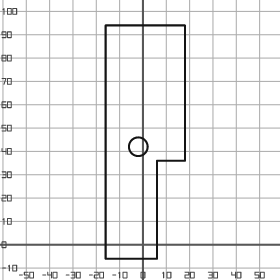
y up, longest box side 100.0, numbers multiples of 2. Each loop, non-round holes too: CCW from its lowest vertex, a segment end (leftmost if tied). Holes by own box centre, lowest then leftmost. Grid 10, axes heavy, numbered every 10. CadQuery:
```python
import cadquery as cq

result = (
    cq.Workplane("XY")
    .moveTo(-16.0, -6.0)
    .lineTo(6.0, -6.0)
    .lineTo(6.0, 36.0)
    .lineTo(18.0, 36.0)
    .lineTo(18.0, 94.0)
    .lineTo(-16.0, 94.0)
    .close()
    .moveTo(-2.0, 42.0)
    .circle(4.0)
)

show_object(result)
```